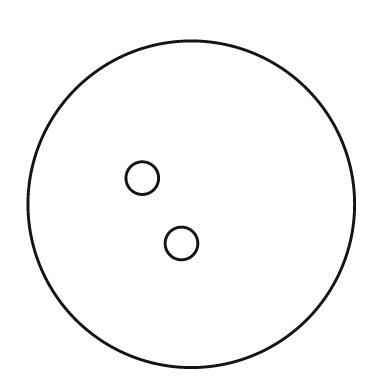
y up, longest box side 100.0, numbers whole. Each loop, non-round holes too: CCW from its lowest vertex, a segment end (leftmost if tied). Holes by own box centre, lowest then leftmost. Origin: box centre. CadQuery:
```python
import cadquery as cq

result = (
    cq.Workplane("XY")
    .moveTo(0.0, 0.0)
    .circle(50.0)
    .moveTo(-3.0, -12.0)
    .circle(5.0)
    .moveTo(-15.0, 8.0)
    .circle(5.0)
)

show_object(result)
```